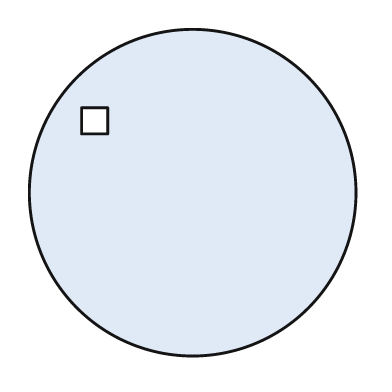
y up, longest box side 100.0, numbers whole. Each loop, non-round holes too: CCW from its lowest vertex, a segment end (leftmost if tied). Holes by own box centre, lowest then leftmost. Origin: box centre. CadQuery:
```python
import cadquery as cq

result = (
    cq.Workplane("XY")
    .moveTo(0.0, 0.0)
    .circle(50.0)
    .moveTo(-34.0, 18.0)
    .lineTo(-26.0, 18.0)
    .lineTo(-26.0, 26.0)
    .lineTo(-34.0, 26.0)
    .close()
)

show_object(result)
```